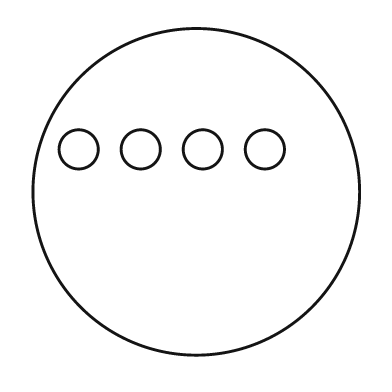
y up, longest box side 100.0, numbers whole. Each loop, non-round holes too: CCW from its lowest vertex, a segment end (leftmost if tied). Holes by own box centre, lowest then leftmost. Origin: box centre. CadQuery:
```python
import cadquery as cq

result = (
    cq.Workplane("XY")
    .moveTo(0.0, 0.0)
    .circle(50.0)
    .moveTo(-36.0, 13.0)
    .circle(6.0)
    .moveTo(-17.0, 13.0)
    .circle(6.0)
    .moveTo(2.0, 13.0)
    .circle(6.0)
    .moveTo(21.0, 13.0)
    .circle(6.0)
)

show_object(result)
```